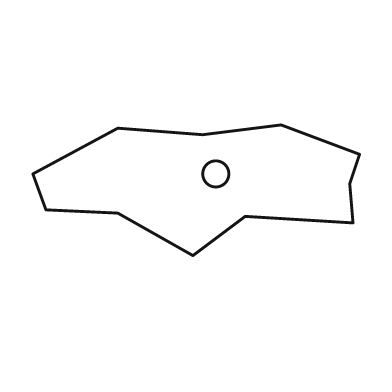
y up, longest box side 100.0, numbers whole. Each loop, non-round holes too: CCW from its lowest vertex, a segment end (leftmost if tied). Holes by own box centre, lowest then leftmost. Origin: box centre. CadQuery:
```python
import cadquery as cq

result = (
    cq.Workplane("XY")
    .moveTo(-1.0, -20.0)
    .lineTo(15.0, -8.0)
    .lineTo(48.0, -10.0)
    .lineTo(47.0, 2.0)
    .lineTo(50.0, 11.0)
    .lineTo(26.0, 20.0)
    .lineTo(2.0, 17.0)
    .lineTo(-24.0, 19.0)
    .lineTo(-50.0, 5.0)
    .lineTo(-46.0, -6.0)
    .lineTo(-24.0, -7.0)
    .close()
    .moveTo(6.0, 5.0)
    .circle(4.0)
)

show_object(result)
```